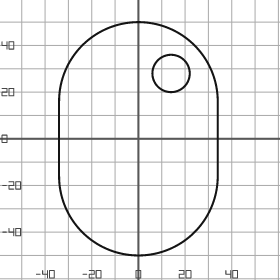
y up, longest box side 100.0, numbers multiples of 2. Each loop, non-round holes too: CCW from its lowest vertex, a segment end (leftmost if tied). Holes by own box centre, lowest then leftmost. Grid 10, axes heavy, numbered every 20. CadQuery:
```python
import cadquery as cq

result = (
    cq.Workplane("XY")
    .moveTo(-34.0, -16.0)
    .threePointArc((0.0, -50.0), (34.0, -16.0))
    .lineTo(34.0, 16.0)
    .threePointArc((0.0, 50.0), (-34.0, 16.0))
    .close()
    .moveTo(14.0, 28.0)
    .circle(8.0)
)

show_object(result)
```